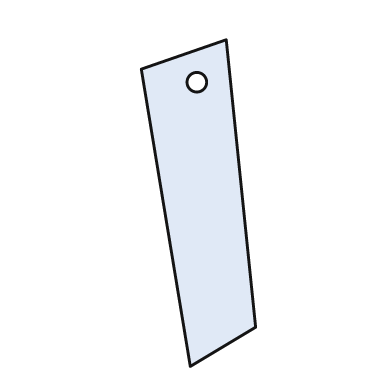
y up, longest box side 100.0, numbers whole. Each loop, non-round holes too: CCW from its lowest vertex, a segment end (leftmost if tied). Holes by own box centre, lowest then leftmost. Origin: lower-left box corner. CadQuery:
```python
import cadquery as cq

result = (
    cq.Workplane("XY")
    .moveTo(15.0, 0.0)
    .lineTo(35.0, 12.0)
    .lineTo(26.0, 100.0)
    .lineTo(0.0, 91.0)
    .close()
    .moveTo(17.0, 87.0)
    .circle(3.0)
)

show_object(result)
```